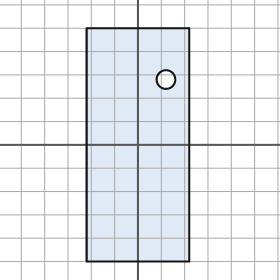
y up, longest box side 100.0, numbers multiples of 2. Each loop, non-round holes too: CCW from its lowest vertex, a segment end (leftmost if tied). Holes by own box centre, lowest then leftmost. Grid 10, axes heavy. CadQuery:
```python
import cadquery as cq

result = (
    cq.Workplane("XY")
    .moveTo(-22.0, -50.0)
    .lineTo(22.0, -50.0)
    .lineTo(22.0, 50.0)
    .lineTo(-22.0, 50.0)
    .close()
    .moveTo(12.0, 28.0)
    .circle(4.0)
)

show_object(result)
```